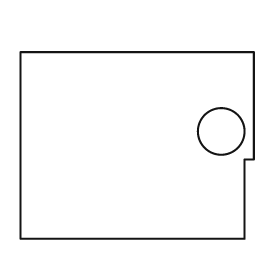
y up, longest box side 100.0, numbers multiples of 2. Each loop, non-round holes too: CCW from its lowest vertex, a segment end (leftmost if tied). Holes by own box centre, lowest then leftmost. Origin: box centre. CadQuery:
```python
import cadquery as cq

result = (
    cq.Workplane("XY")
    .moveTo(-50.0, -40.0)
    .lineTo(46.0, -40.0)
    .lineTo(46.0, -6.0)
    .lineTo(50.0, -6.0)
    .lineTo(50.0, 40.0)
    .lineTo(-50.0, 40.0)
    .close()
    .moveTo(36.0, 6.0)
    .circle(10.0)
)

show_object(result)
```